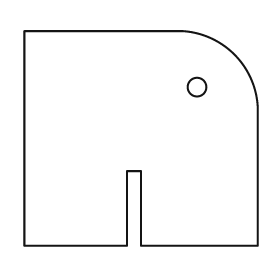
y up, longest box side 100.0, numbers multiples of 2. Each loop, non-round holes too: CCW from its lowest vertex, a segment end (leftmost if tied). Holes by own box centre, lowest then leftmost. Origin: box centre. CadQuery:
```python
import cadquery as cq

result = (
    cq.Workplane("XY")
    .moveTo(-50.0, -46.0)
    .lineTo(-6.0, -46.0)
    .lineTo(-6.0, -14.0)
    .lineTo(0.0, -14.0)
    .lineTo(0.0, -46.0)
    .lineTo(50.0, -46.0)
    .lineTo(50.0, 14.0)
    .threePointArc((40.0, 36.0), (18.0, 46.0))
    .lineTo(-50.0, 46.0)
    .close()
    .moveTo(24.0, 22.0)
    .circle(4.0)
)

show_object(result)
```